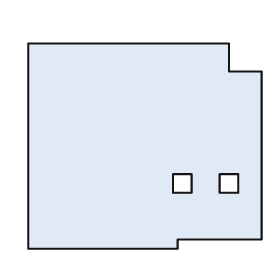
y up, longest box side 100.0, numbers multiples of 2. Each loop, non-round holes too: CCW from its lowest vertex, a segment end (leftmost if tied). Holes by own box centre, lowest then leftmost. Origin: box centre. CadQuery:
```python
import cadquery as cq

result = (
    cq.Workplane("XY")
    .moveTo(-50.0, -44.0)
    .lineTo(14.0, -44.0)
    .lineTo(14.0, -40.0)
    .lineTo(50.0, -40.0)
    .lineTo(50.0, 32.0)
    .lineTo(36.0, 32.0)
    .lineTo(36.0, 44.0)
    .lineTo(-50.0, 44.0)
    .close()
    .moveTo(12.0, -20.0)
    .lineTo(20.0, -20.0)
    .lineTo(20.0, -12.0)
    .lineTo(12.0, -12.0)
    .close()
    .moveTo(32.0, -20.0)
    .lineTo(40.0, -20.0)
    .lineTo(40.0, -12.0)
    .lineTo(32.0, -12.0)
    .close()
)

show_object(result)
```